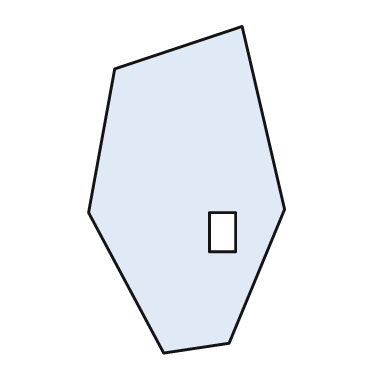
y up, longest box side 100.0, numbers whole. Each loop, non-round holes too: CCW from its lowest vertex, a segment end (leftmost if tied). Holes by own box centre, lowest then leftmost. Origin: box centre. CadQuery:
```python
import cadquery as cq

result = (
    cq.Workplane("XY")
    .moveTo(-7.0, -50.0)
    .lineTo(13.0, -47.0)
    .lineTo(30.0, -6.0)
    .lineTo(17.0, 50.0)
    .lineTo(-22.0, 37.0)
    .lineTo(-30.0, -7.0)
    .close()
    .moveTo(7.0, -19.0)
    .lineTo(15.0, -19.0)
    .lineTo(15.0, -7.0)
    .lineTo(7.0, -7.0)
    .close()
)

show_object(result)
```